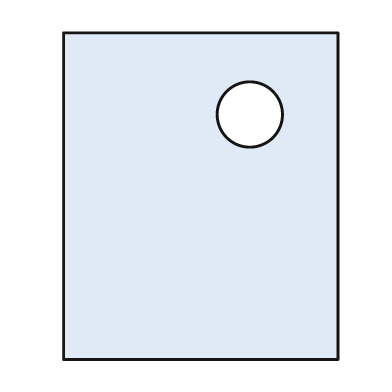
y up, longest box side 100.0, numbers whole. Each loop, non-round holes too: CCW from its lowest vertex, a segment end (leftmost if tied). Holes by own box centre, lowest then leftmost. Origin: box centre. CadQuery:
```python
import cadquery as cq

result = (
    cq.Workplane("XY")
    .moveTo(-42.0, -50.0)
    .lineTo(42.0, -50.0)
    .lineTo(42.0, 50.0)
    .lineTo(-42.0, 50.0)
    .close()
    .moveTo(15.0, 25.0)
    .circle(10.0)
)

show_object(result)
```